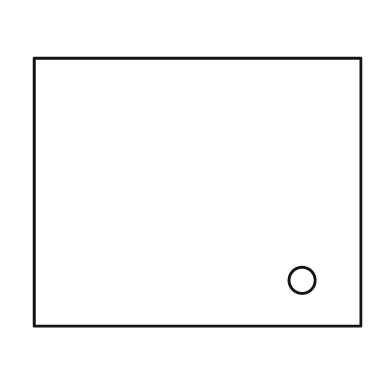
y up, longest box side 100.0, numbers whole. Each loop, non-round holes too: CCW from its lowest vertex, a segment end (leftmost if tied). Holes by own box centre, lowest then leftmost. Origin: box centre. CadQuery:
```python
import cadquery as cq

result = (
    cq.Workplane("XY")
    .moveTo(-50.0, -41.0)
    .lineTo(50.0, -41.0)
    .lineTo(50.0, 41.0)
    .lineTo(-50.0, 41.0)
    .close()
    .moveTo(32.0, -27.0)
    .circle(4.0)
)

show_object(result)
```